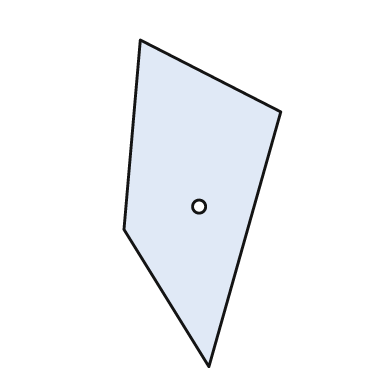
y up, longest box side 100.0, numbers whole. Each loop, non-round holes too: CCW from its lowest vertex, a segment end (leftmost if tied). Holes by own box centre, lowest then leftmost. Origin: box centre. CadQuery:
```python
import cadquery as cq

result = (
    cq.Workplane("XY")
    .moveTo(2.0, -50.0)
    .lineTo(24.0, 28.0)
    .lineTo(-19.0, 50.0)
    .lineTo(-24.0, -8.0)
    .close()
    .moveTo(-1.0, -1.0)
    .circle(2.0)
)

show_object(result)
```